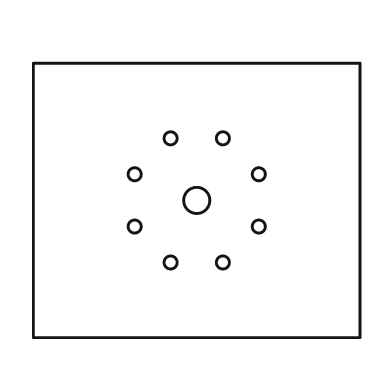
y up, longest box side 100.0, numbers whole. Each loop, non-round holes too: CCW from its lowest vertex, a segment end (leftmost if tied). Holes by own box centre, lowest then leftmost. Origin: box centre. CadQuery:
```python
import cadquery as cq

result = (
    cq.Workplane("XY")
    .moveTo(-50.0, -42.0)
    .lineTo(50.0, -42.0)
    .lineTo(50.0, 42.0)
    .lineTo(-50.0, 42.0)
    .close()
    .moveTo(-8.0, -19.0)
    .circle(2.0)
    .moveTo(8.0, -19.0)
    .circle(2.0)
    .moveTo(-19.0, -8.0)
    .circle(2.0)
    .moveTo(19.0, -8.0)
    .circle(2.0)
    .moveTo(0.0, 0.0)
    .circle(4.0)
    .moveTo(-19.0, 8.0)
    .circle(2.0)
    .moveTo(19.0, 8.0)
    .circle(2.0)
    .moveTo(-8.0, 19.0)
    .circle(2.0)
    .moveTo(8.0, 19.0)
    .circle(2.0)
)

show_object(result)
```